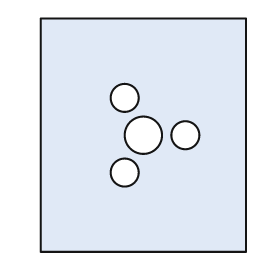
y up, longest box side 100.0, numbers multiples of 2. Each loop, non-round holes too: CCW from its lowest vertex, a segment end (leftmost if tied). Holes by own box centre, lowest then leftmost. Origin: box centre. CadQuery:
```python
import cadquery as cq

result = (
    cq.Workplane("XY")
    .moveTo(-44.0, -50.0)
    .lineTo(44.0, -50.0)
    .lineTo(44.0, 50.0)
    .lineTo(-44.0, 50.0)
    .close()
    .moveTo(-8.0, -16.0)
    .circle(6.0)
    .moveTo(0.0, 0.0)
    .circle(8.0)
    .moveTo(18.0, 0.0)
    .circle(6.0)
    .moveTo(-8.0, 16.0)
    .circle(6.0)
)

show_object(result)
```